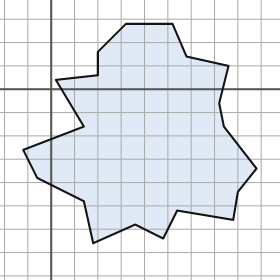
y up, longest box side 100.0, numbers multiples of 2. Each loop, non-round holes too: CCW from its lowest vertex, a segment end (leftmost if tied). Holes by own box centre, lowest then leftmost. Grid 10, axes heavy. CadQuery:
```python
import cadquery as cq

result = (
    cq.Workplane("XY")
    .moveTo(18.0, -66.0)
    .lineTo(36.0, -58.0)
    .lineTo(48.0, -64.0)
    .lineTo(54.0, -52.0)
    .lineTo(78.0, -56.0)
    .lineTo(80.0, -44.0)
    .lineTo(88.0, -34.0)
    .lineTo(74.0, -16.0)
    .lineTo(72.0, -6.0)
    .lineTo(76.0, 10.0)
    .lineTo(58.0, 14.0)
    .lineTo(52.0, 28.0)
    .lineTo(32.0, 28.0)
    .lineTo(20.0, 16.0)
    .lineTo(20.0, 6.0)
    .lineTo(2.0, 4.0)
    .lineTo(14.0, -16.0)
    .lineTo(-12.0, -26.0)
    .lineTo(-6.0, -38.0)
    .lineTo(14.0, -48.0)
    .close()
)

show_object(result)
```